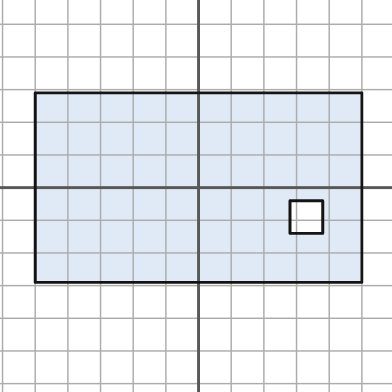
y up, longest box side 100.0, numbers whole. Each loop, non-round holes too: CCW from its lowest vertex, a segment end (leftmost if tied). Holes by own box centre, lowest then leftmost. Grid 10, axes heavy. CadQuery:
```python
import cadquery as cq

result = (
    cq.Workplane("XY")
    .moveTo(-50.0, -29.0)
    .lineTo(50.0, -29.0)
    .lineTo(50.0, 29.0)
    .lineTo(-50.0, 29.0)
    .close()
    .moveTo(28.0, -14.0)
    .lineTo(38.0, -14.0)
    .lineTo(38.0, -4.0)
    .lineTo(28.0, -4.0)
    .close()
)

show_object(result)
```